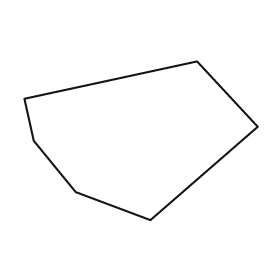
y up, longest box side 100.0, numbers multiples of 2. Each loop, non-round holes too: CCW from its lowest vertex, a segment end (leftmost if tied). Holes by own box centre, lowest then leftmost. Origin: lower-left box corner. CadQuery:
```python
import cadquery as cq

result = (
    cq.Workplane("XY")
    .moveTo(54.0, 0.0)
    .lineTo(100.0, 40.0)
    .lineTo(74.0, 68.0)
    .lineTo(0.0, 52.0)
    .lineTo(4.0, 34.0)
    .lineTo(22.0, 12.0)
    .close()
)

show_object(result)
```